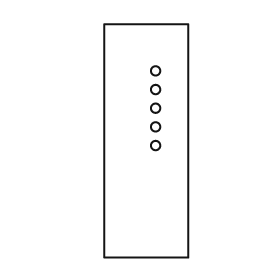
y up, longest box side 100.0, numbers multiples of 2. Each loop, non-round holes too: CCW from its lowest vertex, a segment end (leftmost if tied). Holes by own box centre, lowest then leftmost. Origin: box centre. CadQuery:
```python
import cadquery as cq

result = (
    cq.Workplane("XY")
    .moveTo(-18.0, -50.0)
    .lineTo(18.0, -50.0)
    .lineTo(18.0, 50.0)
    .lineTo(-18.0, 50.0)
    .close()
    .moveTo(4.0, -2.0)
    .circle(2.0)
    .moveTo(4.0, 6.0)
    .circle(2.0)
    .moveTo(4.0, 14.0)
    .circle(2.0)
    .moveTo(4.0, 22.0)
    .circle(2.0)
    .moveTo(4.0, 30.0)
    .circle(2.0)
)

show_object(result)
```